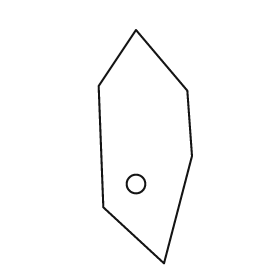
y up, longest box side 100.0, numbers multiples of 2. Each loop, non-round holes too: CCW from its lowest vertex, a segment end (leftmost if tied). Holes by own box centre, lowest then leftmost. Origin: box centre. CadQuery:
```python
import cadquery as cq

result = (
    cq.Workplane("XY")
    .moveTo(8.0, -50.0)
    .lineTo(20.0, -4.0)
    .lineTo(18.0, 24.0)
    .lineTo(-4.0, 50.0)
    .lineTo(-20.0, 26.0)
    .lineTo(-18.0, -26.0)
    .close()
    .moveTo(-4.0, -16.0)
    .circle(4.0)
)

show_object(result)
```